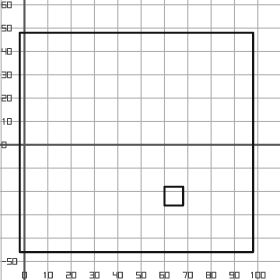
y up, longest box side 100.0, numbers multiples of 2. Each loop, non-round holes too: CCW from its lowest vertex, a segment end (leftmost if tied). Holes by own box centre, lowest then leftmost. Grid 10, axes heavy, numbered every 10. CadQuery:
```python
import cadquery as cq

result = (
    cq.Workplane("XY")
    .moveTo(-2.0, -46.0)
    .lineTo(98.0, -46.0)
    .lineTo(98.0, 48.0)
    .lineTo(-2.0, 48.0)
    .close()
    .moveTo(60.0, -26.0)
    .lineTo(68.0, -26.0)
    .lineTo(68.0, -18.0)
    .lineTo(60.0, -18.0)
    .close()
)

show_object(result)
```